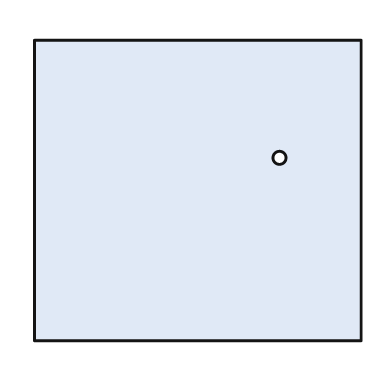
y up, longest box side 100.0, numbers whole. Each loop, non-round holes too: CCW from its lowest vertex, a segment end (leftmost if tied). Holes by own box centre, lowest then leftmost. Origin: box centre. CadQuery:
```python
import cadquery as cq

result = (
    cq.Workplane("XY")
    .moveTo(-50.0, -46.0)
    .lineTo(50.0, -46.0)
    .lineTo(50.0, 46.0)
    .lineTo(-50.0, 46.0)
    .close()
    .moveTo(25.0, 10.0)
    .circle(2.0)
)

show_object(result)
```